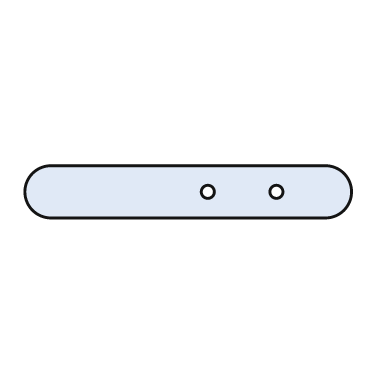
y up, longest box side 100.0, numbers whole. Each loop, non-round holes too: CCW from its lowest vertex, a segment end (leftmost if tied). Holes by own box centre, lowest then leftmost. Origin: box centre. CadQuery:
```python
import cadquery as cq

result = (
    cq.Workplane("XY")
    .moveTo(-42.0, -8.0)
    .lineTo(42.0, -8.0)
    .threePointArc((50.0, 0.0), (42.0, 8.0))
    .lineTo(-42.0, 8.0)
    .threePointArc((-50.0, 0.0), (-42.0, -8.0))
    .close()
    .moveTo(6.0, 0.0)
    .circle(2.0)
    .moveTo(27.0, 0.0)
    .circle(2.0)
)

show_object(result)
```